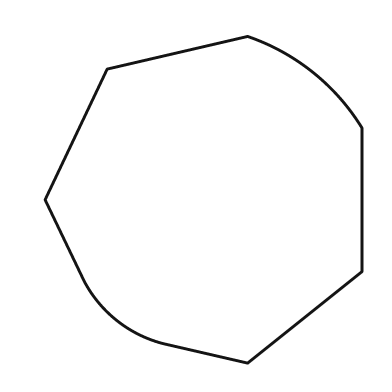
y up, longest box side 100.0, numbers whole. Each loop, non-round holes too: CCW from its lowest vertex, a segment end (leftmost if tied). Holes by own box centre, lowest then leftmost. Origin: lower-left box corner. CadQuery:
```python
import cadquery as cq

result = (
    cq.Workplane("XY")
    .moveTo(62.0, 0.0)
    .lineTo(97.0, 28.0)
    .lineTo(97.0, 72.0)
    .threePointArc((82.0, 89.0), (62.0, 100.0))
    .lineTo(19.0, 90.0)
    .lineTo(0.0, 50.0)
    .lineTo(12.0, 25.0)
    .threePointArc((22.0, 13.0), (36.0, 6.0))
    .close()
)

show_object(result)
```